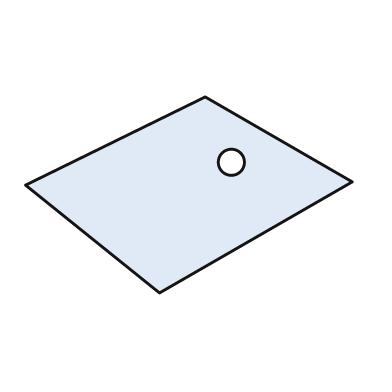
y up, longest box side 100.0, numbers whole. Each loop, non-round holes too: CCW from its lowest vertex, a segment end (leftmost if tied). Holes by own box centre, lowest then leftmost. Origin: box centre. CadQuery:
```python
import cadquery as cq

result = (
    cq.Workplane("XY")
    .moveTo(-9.0, -30.0)
    .lineTo(50.0, 4.0)
    .lineTo(5.0, 30.0)
    .lineTo(-50.0, 3.0)
    .close()
    .moveTo(13.0, 10.0)
    .circle(4.0)
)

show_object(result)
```